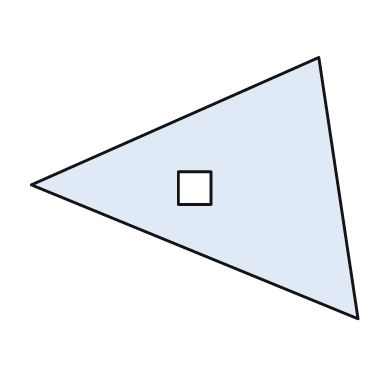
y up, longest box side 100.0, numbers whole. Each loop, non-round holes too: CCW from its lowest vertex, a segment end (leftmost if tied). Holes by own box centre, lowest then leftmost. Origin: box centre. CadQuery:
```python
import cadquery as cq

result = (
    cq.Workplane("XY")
    .moveTo(50.0, -40.0)
    .lineTo(38.0, 40.0)
    .lineTo(-50.0, 1.0)
    .close()
    .moveTo(-5.0, -5.0)
    .lineTo(5.0, -5.0)
    .lineTo(5.0, 5.0)
    .lineTo(-5.0, 5.0)
    .close()
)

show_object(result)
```